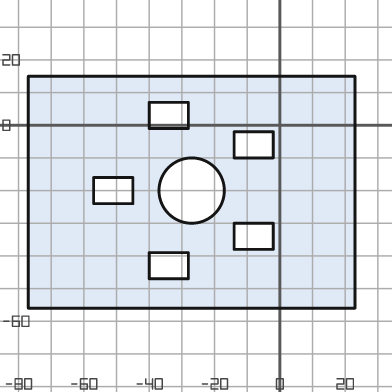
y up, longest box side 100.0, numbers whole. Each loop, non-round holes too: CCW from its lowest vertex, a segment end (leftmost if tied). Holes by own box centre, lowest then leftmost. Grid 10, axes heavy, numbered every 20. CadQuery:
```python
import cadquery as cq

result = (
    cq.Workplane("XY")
    .moveTo(-77.0, -56.0)
    .lineTo(23.0, -56.0)
    .lineTo(23.0, 15.0)
    .lineTo(-77.0, 15.0)
    .close()
    .moveTo(-40.0, -47.0)
    .lineTo(-28.0, -47.0)
    .lineTo(-28.0, -39.0)
    .lineTo(-40.0, -39.0)
    .close()
    .moveTo(-14.0, -38.0)
    .lineTo(-2.0, -38.0)
    .lineTo(-2.0, -30.0)
    .lineTo(-14.0, -30.0)
    .close()
    .moveTo(-57.0, -24.0)
    .lineTo(-45.0, -24.0)
    .lineTo(-45.0, -16.0)
    .lineTo(-57.0, -16.0)
    .close()
    .moveTo(-27.0, -20.0)
    .circle(10.0)
    .moveTo(-14.0, -10.0)
    .lineTo(-2.0, -10.0)
    .lineTo(-2.0, -2.0)
    .lineTo(-14.0, -2.0)
    .close()
    .moveTo(-40.0, -1.0)
    .lineTo(-28.0, -1.0)
    .lineTo(-28.0, 7.0)
    .lineTo(-40.0, 7.0)
    .close()
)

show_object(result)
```